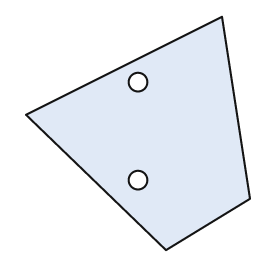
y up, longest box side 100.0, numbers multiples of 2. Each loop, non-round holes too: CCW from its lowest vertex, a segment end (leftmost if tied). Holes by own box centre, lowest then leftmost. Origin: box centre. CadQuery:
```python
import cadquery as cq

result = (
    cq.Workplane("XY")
    .moveTo(12.0, -50.0)
    .lineTo(48.0, -28.0)
    .lineTo(36.0, 50.0)
    .lineTo(-48.0, 8.0)
    .close()
    .moveTo(0.0, -20.0)
    .circle(4.0)
    .moveTo(0.0, 22.0)
    .circle(4.0)
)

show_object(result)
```